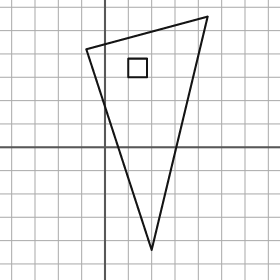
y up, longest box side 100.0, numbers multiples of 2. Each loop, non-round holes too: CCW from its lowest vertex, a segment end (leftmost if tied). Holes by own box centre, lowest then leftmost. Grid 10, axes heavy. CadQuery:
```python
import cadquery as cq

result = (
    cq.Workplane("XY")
    .moveTo(20.0, -44.0)
    .lineTo(44.0, 56.0)
    .lineTo(-8.0, 42.0)
    .close()
    .moveTo(10.0, 30.0)
    .lineTo(18.0, 30.0)
    .lineTo(18.0, 38.0)
    .lineTo(10.0, 38.0)
    .close()
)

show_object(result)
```